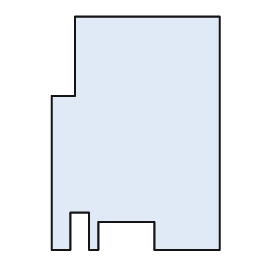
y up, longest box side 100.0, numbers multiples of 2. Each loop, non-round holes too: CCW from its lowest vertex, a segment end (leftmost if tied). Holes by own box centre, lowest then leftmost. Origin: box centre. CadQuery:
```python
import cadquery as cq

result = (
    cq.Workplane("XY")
    .moveTo(-36.0, -50.0)
    .lineTo(-28.0, -50.0)
    .lineTo(-28.0, -34.0)
    .lineTo(-20.0, -34.0)
    .lineTo(-20.0, -50.0)
    .lineTo(-16.0, -50.0)
    .lineTo(-16.0, -38.0)
    .lineTo(8.0, -38.0)
    .lineTo(8.0, -50.0)
    .lineTo(36.0, -50.0)
    .lineTo(36.0, 50.0)
    .lineTo(-26.0, 50.0)
    .lineTo(-26.0, 16.0)
    .lineTo(-36.0, 16.0)
    .close()
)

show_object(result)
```